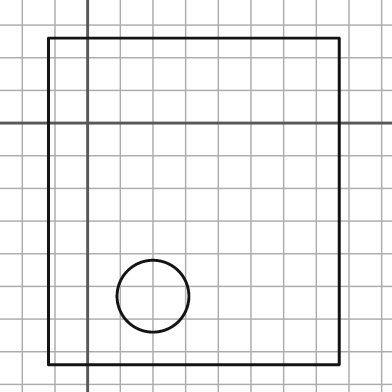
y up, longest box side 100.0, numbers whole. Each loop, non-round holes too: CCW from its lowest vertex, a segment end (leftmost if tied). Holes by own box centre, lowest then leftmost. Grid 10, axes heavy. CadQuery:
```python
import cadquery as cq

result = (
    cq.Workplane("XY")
    .moveTo(-12.0, -74.0)
    .lineTo(77.0, -74.0)
    .lineTo(77.0, 26.0)
    .lineTo(-12.0, 26.0)
    .close()
    .moveTo(20.0, -53.0)
    .circle(11.0)
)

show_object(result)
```